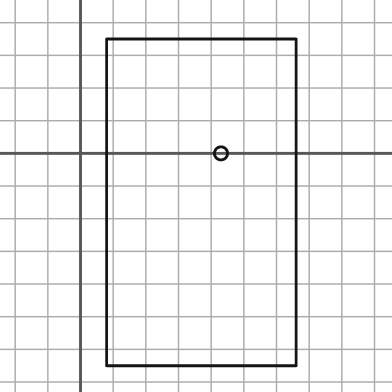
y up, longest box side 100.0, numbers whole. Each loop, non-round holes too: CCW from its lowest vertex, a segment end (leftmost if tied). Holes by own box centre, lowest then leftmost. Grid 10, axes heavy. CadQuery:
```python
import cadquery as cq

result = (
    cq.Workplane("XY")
    .moveTo(8.0, -65.0)
    .lineTo(66.0, -65.0)
    .lineTo(66.0, 35.0)
    .lineTo(8.0, 35.0)
    .close()
    .moveTo(43.0, 0.0)
    .circle(2.0)
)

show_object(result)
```